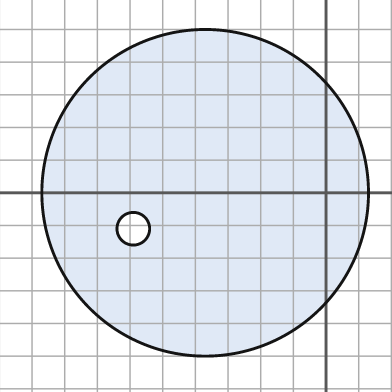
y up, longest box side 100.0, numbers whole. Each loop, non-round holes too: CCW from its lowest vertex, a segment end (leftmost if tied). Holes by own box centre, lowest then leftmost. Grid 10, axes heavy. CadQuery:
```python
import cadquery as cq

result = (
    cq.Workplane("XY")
    .moveTo(-37.0, 0.0)
    .circle(50.0)
    .moveTo(-59.0, -11.0)
    .circle(5.0)
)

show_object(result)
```